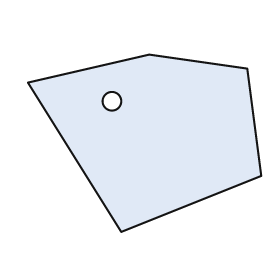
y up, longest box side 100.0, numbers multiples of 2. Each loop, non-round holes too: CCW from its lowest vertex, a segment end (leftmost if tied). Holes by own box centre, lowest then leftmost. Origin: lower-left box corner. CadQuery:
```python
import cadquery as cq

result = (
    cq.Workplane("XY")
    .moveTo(40.0, 0.0)
    .lineTo(100.0, 24.0)
    .lineTo(94.0, 70.0)
    .lineTo(52.0, 76.0)
    .lineTo(0.0, 64.0)
    .close()
    .moveTo(36.0, 56.0)
    .circle(4.0)
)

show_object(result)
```